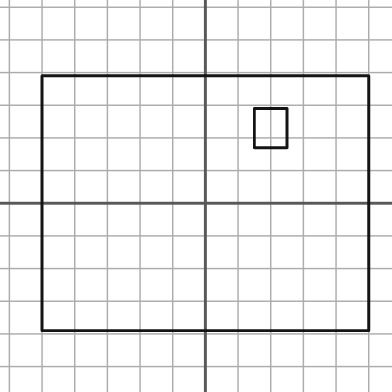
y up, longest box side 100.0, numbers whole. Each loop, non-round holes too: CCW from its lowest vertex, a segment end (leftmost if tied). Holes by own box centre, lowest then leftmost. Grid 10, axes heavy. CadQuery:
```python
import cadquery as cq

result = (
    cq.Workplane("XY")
    .moveTo(-50.0, -39.0)
    .lineTo(50.0, -39.0)
    .lineTo(50.0, 39.0)
    .lineTo(-50.0, 39.0)
    .close()
    .moveTo(15.0, 17.0)
    .lineTo(25.0, 17.0)
    .lineTo(25.0, 29.0)
    .lineTo(15.0, 29.0)
    .close()
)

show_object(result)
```